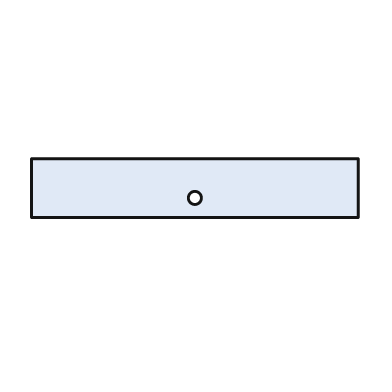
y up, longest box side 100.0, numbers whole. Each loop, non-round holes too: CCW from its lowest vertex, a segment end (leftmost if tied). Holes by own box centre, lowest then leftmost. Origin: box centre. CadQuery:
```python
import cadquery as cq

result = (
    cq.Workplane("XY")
    .moveTo(-50.0, -9.0)
    .lineTo(50.0, -9.0)
    .lineTo(50.0, 9.0)
    .lineTo(-50.0, 9.0)
    .close()
    .moveTo(0.0, -3.0)
    .circle(2.0)
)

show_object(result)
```